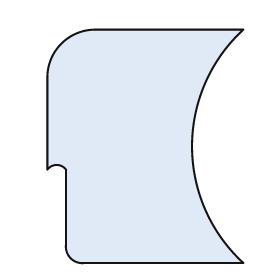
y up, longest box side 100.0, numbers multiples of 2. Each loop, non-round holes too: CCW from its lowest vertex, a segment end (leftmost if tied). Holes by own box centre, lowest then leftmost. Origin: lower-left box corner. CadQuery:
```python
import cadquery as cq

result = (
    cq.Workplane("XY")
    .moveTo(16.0, 0.0)
    .lineTo(84.0, 0.0)
    .threePointArc((62.0, 50.0), (84.0, 100.0))
    .lineTo(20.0, 100.0)
    .threePointArc((6.0, 94.0), (0.0, 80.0))
    .lineTo(0.0, 40.0)
    .threePointArc((4.0, 42.0), (8.0, 40.0))
    .lineTo(8.0, 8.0)
    .threePointArc((10.0, 2.0), (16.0, 0.0))
    .close()
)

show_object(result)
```